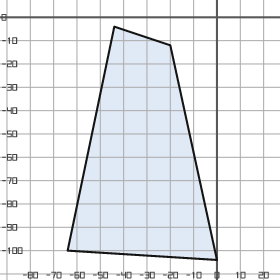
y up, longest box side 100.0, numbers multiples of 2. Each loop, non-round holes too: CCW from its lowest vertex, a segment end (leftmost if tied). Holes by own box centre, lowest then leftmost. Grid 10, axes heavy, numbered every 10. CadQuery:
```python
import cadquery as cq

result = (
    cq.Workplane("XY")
    .moveTo(0.0, -104.0)
    .lineTo(-20.0, -12.0)
    .lineTo(-44.0, -4.0)
    .lineTo(-64.0, -100.0)
    .close()
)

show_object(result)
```